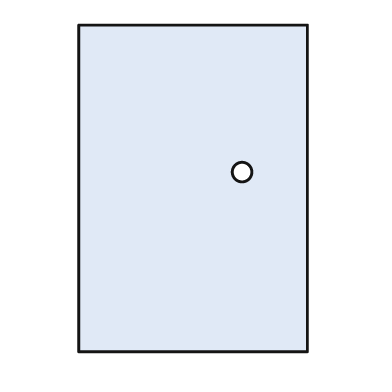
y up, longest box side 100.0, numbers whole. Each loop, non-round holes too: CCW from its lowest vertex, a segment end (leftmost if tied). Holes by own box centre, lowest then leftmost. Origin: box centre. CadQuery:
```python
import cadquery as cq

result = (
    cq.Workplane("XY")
    .moveTo(-35.0, -50.0)
    .lineTo(35.0, -50.0)
    .lineTo(35.0, 50.0)
    .lineTo(-35.0, 50.0)
    .close()
    .moveTo(15.0, 5.0)
    .circle(3.0)
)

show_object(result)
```